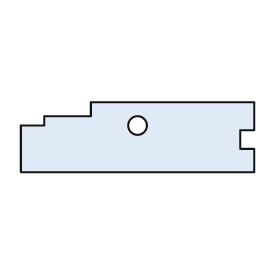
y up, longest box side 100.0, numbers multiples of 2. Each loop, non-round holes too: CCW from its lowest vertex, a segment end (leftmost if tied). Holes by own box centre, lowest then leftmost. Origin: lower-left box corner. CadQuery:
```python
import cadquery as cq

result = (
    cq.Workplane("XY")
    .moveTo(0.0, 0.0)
    .lineTo(100.0, 0.0)
    .lineTo(100.0, 10.0)
    .lineTo(94.0, 10.0)
    .lineTo(94.0, 18.0)
    .lineTo(100.0, 18.0)
    .lineTo(100.0, 30.0)
    .lineTo(30.0, 30.0)
    .lineTo(30.0, 24.0)
    .lineTo(10.0, 24.0)
    .lineTo(10.0, 20.0)
    .lineTo(0.0, 20.0)
    .close()
    .moveTo(50.0, 20.0)
    .circle(4.0)
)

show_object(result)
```